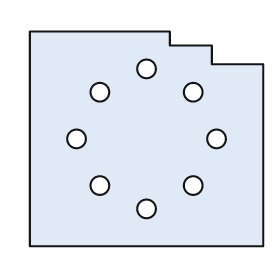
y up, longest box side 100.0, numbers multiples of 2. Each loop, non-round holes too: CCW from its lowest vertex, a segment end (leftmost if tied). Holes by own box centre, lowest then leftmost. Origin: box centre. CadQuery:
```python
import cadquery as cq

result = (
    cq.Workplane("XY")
    .moveTo(-50.0, -46.0)
    .lineTo(50.0, -46.0)
    .lineTo(50.0, 32.0)
    .lineTo(28.0, 32.0)
    .lineTo(28.0, 40.0)
    .lineTo(10.0, 40.0)
    .lineTo(10.0, 46.0)
    .lineTo(-50.0, 46.0)
    .close()
    .moveTo(0.0, -30.0)
    .circle(4.0)
    .moveTo(-20.0, -20.0)
    .circle(4.0)
    .moveTo(20.0, -20.0)
    .circle(4.0)
    .moveTo(-30.0, 0.0)
    .circle(4.0)
    .moveTo(30.0, 0.0)
    .circle(4.0)
    .moveTo(-20.0, 20.0)
    .circle(4.0)
    .moveTo(20.0, 20.0)
    .circle(4.0)
    .moveTo(0.0, 30.0)
    .circle(4.0)
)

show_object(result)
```